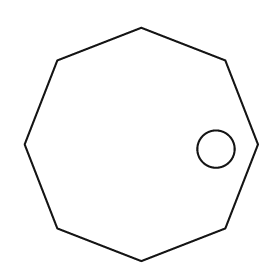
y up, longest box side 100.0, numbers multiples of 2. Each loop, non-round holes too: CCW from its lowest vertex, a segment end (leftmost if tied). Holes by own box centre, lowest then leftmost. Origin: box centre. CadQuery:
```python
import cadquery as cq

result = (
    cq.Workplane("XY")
    .moveTo(0.0, -50.0)
    .lineTo(36.0, -36.0)
    .lineTo(50.0, 0.0)
    .lineTo(36.0, 36.0)
    .lineTo(0.0, 50.0)
    .lineTo(-36.0, 36.0)
    .lineTo(-50.0, 0.0)
    .lineTo(-36.0, -36.0)
    .close()
    .moveTo(32.0, -2.0)
    .circle(8.0)
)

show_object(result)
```